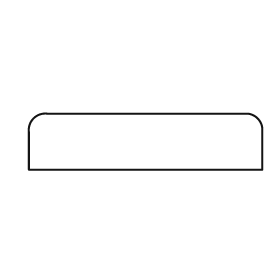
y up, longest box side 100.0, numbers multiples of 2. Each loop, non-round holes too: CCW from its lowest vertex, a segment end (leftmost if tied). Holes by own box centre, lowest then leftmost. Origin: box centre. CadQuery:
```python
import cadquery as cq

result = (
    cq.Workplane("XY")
    .moveTo(-50.0, -12.0)
    .lineTo(50.0, -12.0)
    .lineTo(50.0, 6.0)
    .threePointArc((48.0, 10.0), (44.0, 12.0))
    .lineTo(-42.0, 12.0)
    .threePointArc((-48.0, 10.0), (-50.0, 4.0))
    .close()
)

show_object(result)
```